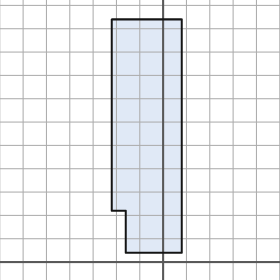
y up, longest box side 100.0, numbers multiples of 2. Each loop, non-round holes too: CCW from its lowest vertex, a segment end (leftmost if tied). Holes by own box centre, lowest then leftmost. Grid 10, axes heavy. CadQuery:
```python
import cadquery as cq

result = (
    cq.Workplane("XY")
    .moveTo(-16.0, 4.0)
    .lineTo(8.0, 4.0)
    .lineTo(8.0, 104.0)
    .lineTo(-22.0, 104.0)
    .lineTo(-22.0, 22.0)
    .lineTo(-16.0, 22.0)
    .close()
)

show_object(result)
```